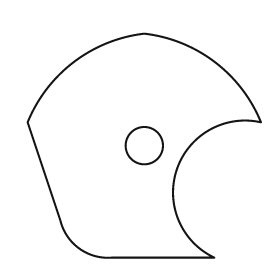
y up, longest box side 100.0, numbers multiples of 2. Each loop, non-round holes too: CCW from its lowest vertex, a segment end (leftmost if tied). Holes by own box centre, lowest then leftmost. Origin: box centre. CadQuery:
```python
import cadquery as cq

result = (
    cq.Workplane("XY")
    .moveTo(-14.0, -48.0)
    .lineTo(30.0, -48.0)
    .threePointArc((14.0, -10.0), (50.0, 10.0))
    .threePointArc((30.0, 36.0), (0.0, 48.0))
    .threePointArc((-30.0, 36.0), (-50.0, 10.0))
    .lineTo(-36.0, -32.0)
    .threePointArc((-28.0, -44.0), (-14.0, -48.0))
    .close()
    .moveTo(0.0, 0.0)
    .circle(8.0)
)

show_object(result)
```